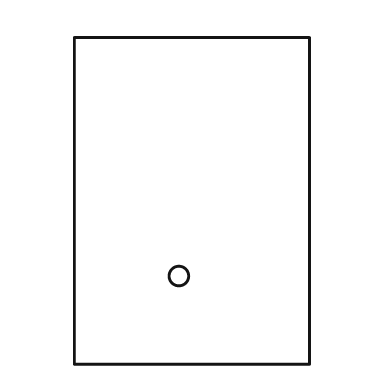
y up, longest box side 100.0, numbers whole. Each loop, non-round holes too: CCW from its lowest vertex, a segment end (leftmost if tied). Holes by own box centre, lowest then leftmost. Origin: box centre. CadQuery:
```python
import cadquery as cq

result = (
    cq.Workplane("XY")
    .moveTo(-36.0, -50.0)
    .lineTo(36.0, -50.0)
    .lineTo(36.0, 50.0)
    .lineTo(-36.0, 50.0)
    .close()
    .moveTo(-4.0, -23.0)
    .circle(3.0)
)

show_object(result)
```